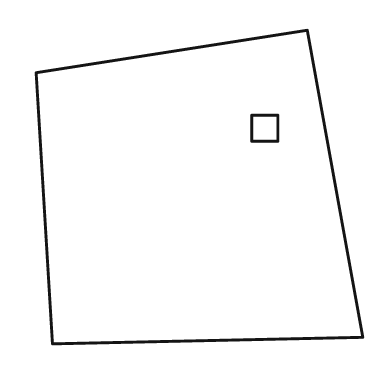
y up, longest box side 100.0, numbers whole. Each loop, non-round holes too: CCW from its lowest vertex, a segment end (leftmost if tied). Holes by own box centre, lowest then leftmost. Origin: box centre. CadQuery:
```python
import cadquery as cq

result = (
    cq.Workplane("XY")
    .moveTo(-45.0, -48.0)
    .lineTo(50.0, -46.0)
    .lineTo(33.0, 48.0)
    .lineTo(-50.0, 35.0)
    .close()
    .moveTo(16.0, 14.0)
    .lineTo(24.0, 14.0)
    .lineTo(24.0, 22.0)
    .lineTo(16.0, 22.0)
    .close()
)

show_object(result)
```